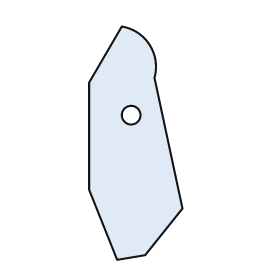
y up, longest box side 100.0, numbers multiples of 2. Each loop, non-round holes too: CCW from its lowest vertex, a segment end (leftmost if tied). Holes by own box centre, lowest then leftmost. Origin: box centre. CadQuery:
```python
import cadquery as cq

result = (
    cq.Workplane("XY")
    .moveTo(-8.0, -50.0)
    .lineTo(4.0, -48.0)
    .lineTo(20.0, -28.0)
    .lineTo(8.0, 28.0)
    .threePointArc((6.0, 42.0), (-6.0, 50.0))
    .lineTo(-20.0, 26.0)
    .lineTo(-20.0, -20.0)
    .close()
    .moveTo(-2.0, 12.0)
    .circle(4.0)
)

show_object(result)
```